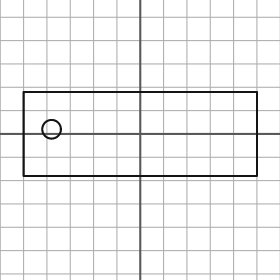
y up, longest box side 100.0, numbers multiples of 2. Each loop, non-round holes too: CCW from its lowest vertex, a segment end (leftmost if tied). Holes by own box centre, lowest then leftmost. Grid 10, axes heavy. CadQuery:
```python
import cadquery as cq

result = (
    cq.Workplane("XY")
    .moveTo(-50.0, -18.0)
    .lineTo(50.0, -18.0)
    .lineTo(50.0, 18.0)
    .lineTo(-50.0, 18.0)
    .close()
    .moveTo(-38.0, 2.0)
    .circle(4.0)
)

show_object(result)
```